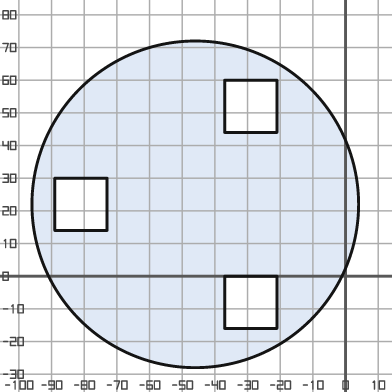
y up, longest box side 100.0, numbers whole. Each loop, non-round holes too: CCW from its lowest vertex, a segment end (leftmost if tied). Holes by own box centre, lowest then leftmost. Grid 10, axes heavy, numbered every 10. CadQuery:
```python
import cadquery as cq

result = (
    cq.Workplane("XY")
    .moveTo(-46.0, 22.0)
    .circle(50.0)
    .moveTo(-37.0, -16.0)
    .lineTo(-21.0, -16.0)
    .lineTo(-21.0, 0.0)
    .lineTo(-37.0, 0.0)
    .close()
    .moveTo(-89.0, 14.0)
    .lineTo(-73.0, 14.0)
    .lineTo(-73.0, 30.0)
    .lineTo(-89.0, 30.0)
    .close()
    .moveTo(-37.0, 44.0)
    .lineTo(-21.0, 44.0)
    .lineTo(-21.0, 60.0)
    .lineTo(-37.0, 60.0)
    .close()
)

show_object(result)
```